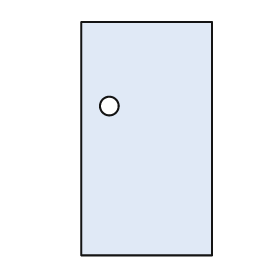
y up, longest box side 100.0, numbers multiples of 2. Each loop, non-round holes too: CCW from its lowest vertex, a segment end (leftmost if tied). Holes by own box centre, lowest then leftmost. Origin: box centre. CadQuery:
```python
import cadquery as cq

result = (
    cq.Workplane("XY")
    .moveTo(-28.0, -50.0)
    .lineTo(28.0, -50.0)
    .lineTo(28.0, 50.0)
    .lineTo(-28.0, 50.0)
    .close()
    .moveTo(-16.0, 14.0)
    .circle(4.0)
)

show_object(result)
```